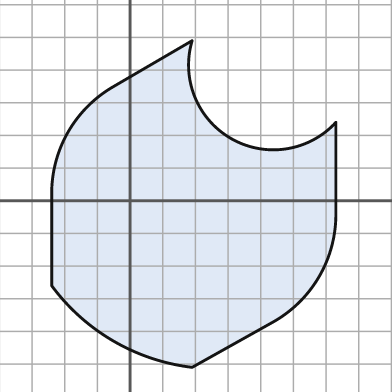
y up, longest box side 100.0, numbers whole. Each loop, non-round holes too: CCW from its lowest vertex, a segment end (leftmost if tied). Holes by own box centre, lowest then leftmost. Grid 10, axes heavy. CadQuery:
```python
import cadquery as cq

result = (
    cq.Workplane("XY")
    .moveTo(19.0, -51.0)
    .lineTo(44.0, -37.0)
    .threePointArc((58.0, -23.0), (63.0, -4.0))
    .lineTo(63.0, 24.0)
    .threePointArc((31.0, 19.0), (19.0, 49.0))
    .lineTo(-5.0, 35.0)
    .threePointArc((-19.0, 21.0), (-24.0, 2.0))
    .lineTo(-24.0, -26.0)
    .threePointArc((-5.0, -43.0), (19.0, -51.0))
    .close()
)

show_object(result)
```